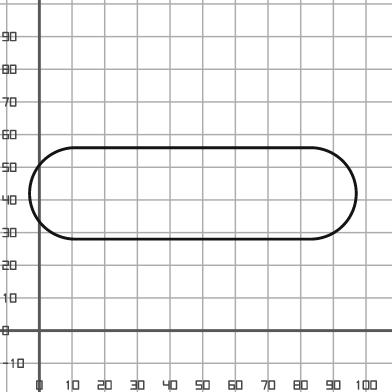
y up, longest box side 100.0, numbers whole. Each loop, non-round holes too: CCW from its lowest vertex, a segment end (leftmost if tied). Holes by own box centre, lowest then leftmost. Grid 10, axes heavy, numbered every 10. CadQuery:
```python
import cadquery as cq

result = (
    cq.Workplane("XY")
    .moveTo(11.0, 28.0)
    .lineTo(83.0, 28.0)
    .threePointArc((97.0, 42.0), (83.0, 56.0))
    .lineTo(11.0, 56.0)
    .threePointArc((-3.0, 42.0), (11.0, 28.0))
    .close()
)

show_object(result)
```